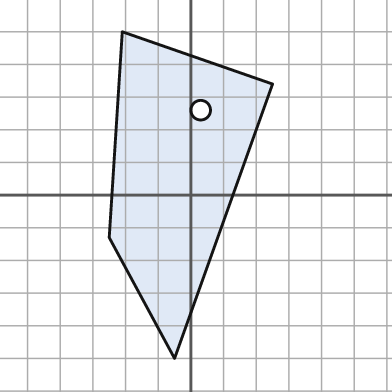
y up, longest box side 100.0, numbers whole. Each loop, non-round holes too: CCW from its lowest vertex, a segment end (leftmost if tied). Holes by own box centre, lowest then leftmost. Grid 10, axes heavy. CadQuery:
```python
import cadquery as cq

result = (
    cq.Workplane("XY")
    .moveTo(-5.0, -50.0)
    .lineTo(25.0, 34.0)
    .lineTo(-21.0, 50.0)
    .lineTo(-25.0, -13.0)
    .close()
    .moveTo(3.0, 26.0)
    .circle(3.0)
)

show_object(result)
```